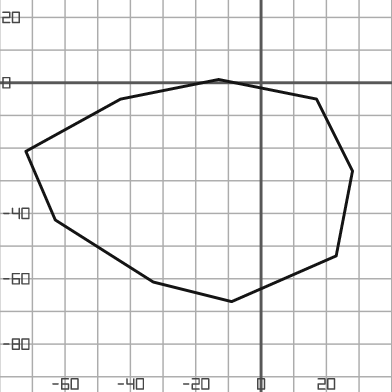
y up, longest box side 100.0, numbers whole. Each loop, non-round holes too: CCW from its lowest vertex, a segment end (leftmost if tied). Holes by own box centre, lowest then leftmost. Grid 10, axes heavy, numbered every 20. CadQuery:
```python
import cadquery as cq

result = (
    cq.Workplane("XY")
    .moveTo(-9.0, -67.0)
    .lineTo(23.0, -53.0)
    .lineTo(28.0, -27.0)
    .lineTo(17.0, -5.0)
    .lineTo(-13.0, 1.0)
    .lineTo(-43.0, -5.0)
    .lineTo(-72.0, -21.0)
    .lineTo(-63.0, -42.0)
    .lineTo(-33.0, -61.0)
    .close()
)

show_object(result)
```